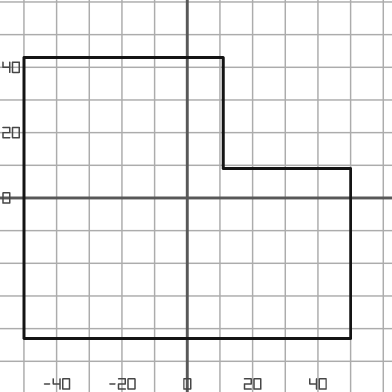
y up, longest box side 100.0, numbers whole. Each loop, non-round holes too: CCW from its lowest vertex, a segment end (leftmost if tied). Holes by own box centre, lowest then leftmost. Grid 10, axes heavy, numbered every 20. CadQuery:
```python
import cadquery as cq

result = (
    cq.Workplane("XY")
    .moveTo(-50.0, -43.0)
    .lineTo(50.0, -43.0)
    .lineTo(50.0, 9.0)
    .lineTo(11.0, 9.0)
    .lineTo(11.0, 43.0)
    .lineTo(-50.0, 43.0)
    .close()
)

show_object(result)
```